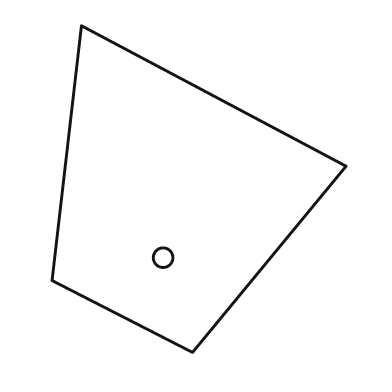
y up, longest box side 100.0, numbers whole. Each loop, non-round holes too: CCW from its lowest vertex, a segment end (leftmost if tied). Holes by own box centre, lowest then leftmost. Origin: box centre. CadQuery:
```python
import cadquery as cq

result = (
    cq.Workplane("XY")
    .moveTo(-2.0, -50.0)
    .lineTo(45.0, 7.0)
    .lineTo(-36.0, 50.0)
    .lineTo(-45.0, -28.0)
    .close()
    .moveTo(-11.0, -21.0)
    .circle(3.0)
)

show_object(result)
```